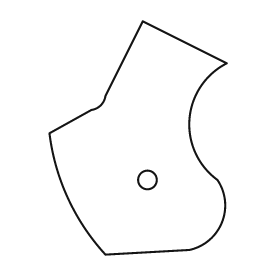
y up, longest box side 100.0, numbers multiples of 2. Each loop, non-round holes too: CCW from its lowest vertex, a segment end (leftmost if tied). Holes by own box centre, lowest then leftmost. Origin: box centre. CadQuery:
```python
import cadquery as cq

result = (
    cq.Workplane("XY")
    .moveTo(-14.0, -50.0)
    .lineTo(22.0, -48.0)
    .threePointArc((36.0, -36.0), (34.0, -18.0))
    .threePointArc((22.0, 8.0), (38.0, 32.0))
    .lineTo(2.0, 50.0)
    .lineTo(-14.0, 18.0)
    .threePointArc((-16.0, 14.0), (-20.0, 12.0))
    .lineTo(-38.0, 2.0)
    .threePointArc((-30.0, -26.0), (-14.0, -50.0))
    .close()
    .moveTo(4.0, -18.0)
    .circle(4.0)
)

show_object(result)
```